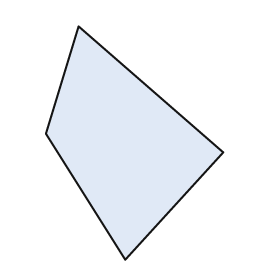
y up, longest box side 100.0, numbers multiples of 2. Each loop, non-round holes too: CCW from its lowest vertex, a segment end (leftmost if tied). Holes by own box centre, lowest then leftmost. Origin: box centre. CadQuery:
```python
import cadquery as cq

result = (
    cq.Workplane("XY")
    .moveTo(-4.0, -50.0)
    .lineTo(38.0, -4.0)
    .lineTo(-24.0, 50.0)
    .lineTo(-38.0, 4.0)
    .close()
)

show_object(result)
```